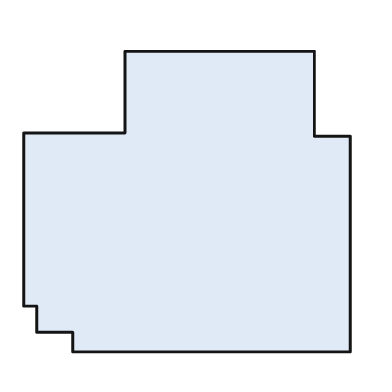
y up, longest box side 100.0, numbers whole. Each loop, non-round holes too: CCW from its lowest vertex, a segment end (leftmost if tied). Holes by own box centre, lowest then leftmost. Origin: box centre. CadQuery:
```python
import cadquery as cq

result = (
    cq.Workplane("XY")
    .moveTo(-35.0, -46.0)
    .lineTo(50.0, -46.0)
    .lineTo(50.0, 20.0)
    .lineTo(39.0, 20.0)
    .lineTo(39.0, 46.0)
    .lineTo(-19.0, 46.0)
    .lineTo(-19.0, 21.0)
    .lineTo(-50.0, 21.0)
    .lineTo(-50.0, -32.0)
    .lineTo(-46.0, -32.0)
    .lineTo(-46.0, -40.0)
    .lineTo(-35.0, -40.0)
    .close()
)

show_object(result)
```